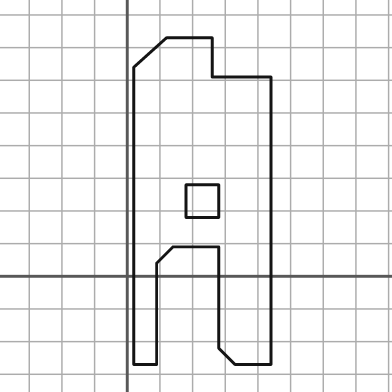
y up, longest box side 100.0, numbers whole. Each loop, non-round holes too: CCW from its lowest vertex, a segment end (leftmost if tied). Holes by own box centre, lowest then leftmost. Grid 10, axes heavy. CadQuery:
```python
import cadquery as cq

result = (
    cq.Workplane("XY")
    .moveTo(2.0, -27.0)
    .lineTo(9.0, -27.0)
    .lineTo(9.0, 4.0)
    .lineTo(14.0, 9.0)
    .lineTo(28.0, 9.0)
    .lineTo(28.0, -22.0)
    .lineTo(33.0, -27.0)
    .lineTo(44.0, -27.0)
    .lineTo(44.0, 61.0)
    .lineTo(26.0, 61.0)
    .lineTo(26.0, 73.0)
    .lineTo(12.0, 73.0)
    .lineTo(2.0, 64.0)
    .close()
    .moveTo(18.0, 18.0)
    .lineTo(28.0, 18.0)
    .lineTo(28.0, 28.0)
    .lineTo(18.0, 28.0)
    .close()
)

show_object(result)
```